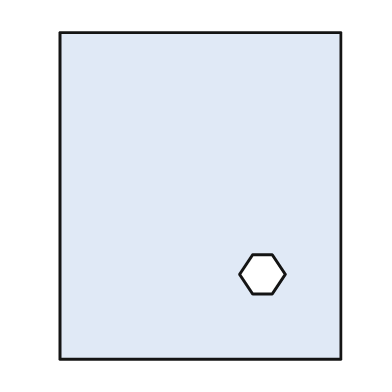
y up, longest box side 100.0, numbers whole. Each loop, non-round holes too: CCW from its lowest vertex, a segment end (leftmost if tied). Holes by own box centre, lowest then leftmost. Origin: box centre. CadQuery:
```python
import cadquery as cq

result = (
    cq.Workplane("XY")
    .moveTo(-43.0, -50.0)
    .lineTo(43.0, -50.0)
    .lineTo(43.0, 50.0)
    .lineTo(-43.0, 50.0)
    .close()
    .moveTo(16.0, -30.0)
    .lineTo(22.0, -30.0)
    .lineTo(26.0, -24.0)
    .lineTo(22.0, -18.0)
    .lineTo(16.0, -18.0)
    .lineTo(12.0, -24.0)
    .close()
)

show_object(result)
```